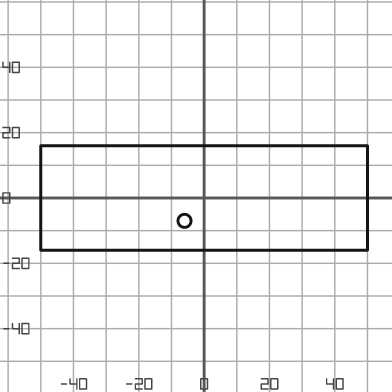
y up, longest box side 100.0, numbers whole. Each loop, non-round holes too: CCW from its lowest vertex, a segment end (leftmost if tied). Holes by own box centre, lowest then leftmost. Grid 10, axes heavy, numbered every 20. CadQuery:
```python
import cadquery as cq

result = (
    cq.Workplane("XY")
    .moveTo(-50.0, -16.0)
    .lineTo(50.0, -16.0)
    .lineTo(50.0, 16.0)
    .lineTo(-50.0, 16.0)
    .close()
    .moveTo(-6.0, -7.0)
    .circle(2.0)
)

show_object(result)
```